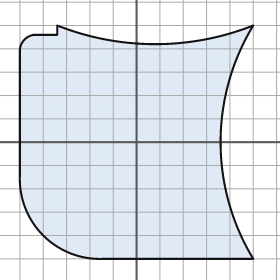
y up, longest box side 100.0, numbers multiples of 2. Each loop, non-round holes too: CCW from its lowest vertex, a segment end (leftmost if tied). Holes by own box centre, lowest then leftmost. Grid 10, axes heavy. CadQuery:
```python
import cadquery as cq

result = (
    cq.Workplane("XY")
    .moveTo(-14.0, -50.0)
    .lineTo(50.0, -50.0)
    .threePointArc((36.0, 0.0), (50.0, 50.0))
    .threePointArc((8.0, 42.0), (-34.0, 50.0))
    .lineTo(-34.0, 46.0)
    .lineTo(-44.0, 46.0)
    .threePointArc((-48.0, 44.0), (-50.0, 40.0))
    .lineTo(-50.0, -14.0)
    .threePointArc((-40.0, -40.0), (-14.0, -50.0))
    .close()
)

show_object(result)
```